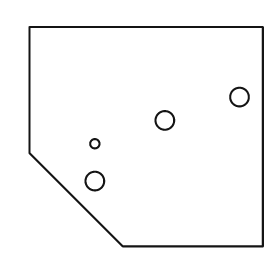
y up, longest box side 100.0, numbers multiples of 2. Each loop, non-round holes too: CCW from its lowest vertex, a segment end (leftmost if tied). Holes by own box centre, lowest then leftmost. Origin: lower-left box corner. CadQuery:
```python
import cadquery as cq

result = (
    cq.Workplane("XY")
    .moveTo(40.0, 0.0)
    .lineTo(100.0, 0.0)
    .lineTo(100.0, 94.0)
    .lineTo(0.0, 94.0)
    .lineTo(0.0, 40.0)
    .close()
    .moveTo(28.0, 28.0)
    .circle(4.0)
    .moveTo(28.0, 44.0)
    .circle(2.0)
    .moveTo(58.0, 54.0)
    .circle(4.0)
    .moveTo(90.0, 64.0)
    .circle(4.0)
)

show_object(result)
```